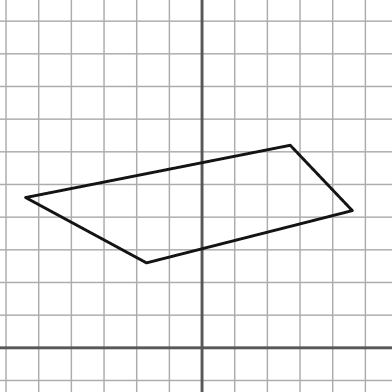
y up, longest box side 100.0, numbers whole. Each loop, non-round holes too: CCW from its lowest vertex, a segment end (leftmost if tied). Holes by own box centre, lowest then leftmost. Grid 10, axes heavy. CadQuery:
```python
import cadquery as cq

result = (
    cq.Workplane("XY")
    .moveTo(-17.0, 26.0)
    .lineTo(46.0, 42.0)
    .lineTo(27.0, 62.0)
    .lineTo(-54.0, 46.0)
    .close()
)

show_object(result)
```